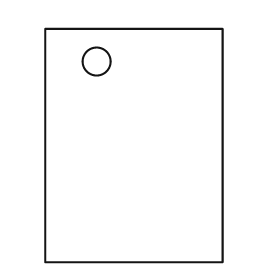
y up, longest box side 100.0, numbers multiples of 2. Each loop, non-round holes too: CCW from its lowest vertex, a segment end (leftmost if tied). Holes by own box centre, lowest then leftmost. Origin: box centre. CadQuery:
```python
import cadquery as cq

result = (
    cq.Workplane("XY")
    .moveTo(-38.0, -50.0)
    .lineTo(38.0, -50.0)
    .lineTo(38.0, 50.0)
    .lineTo(-38.0, 50.0)
    .close()
    .moveTo(-16.0, 36.0)
    .circle(6.0)
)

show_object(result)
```